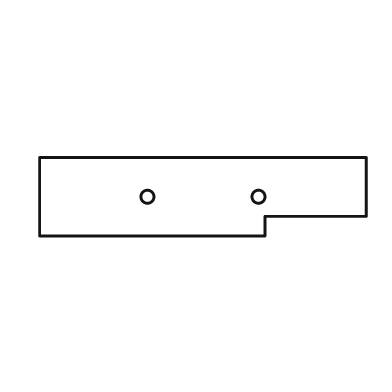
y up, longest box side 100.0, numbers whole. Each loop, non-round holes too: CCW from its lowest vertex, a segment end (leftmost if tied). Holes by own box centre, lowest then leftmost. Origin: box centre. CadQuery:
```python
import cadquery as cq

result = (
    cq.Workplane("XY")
    .moveTo(-50.0, -12.0)
    .lineTo(19.0, -12.0)
    .lineTo(19.0, -6.0)
    .lineTo(50.0, -6.0)
    .lineTo(50.0, 12.0)
    .lineTo(-50.0, 12.0)
    .close()
    .moveTo(-17.0, 0.0)
    .circle(2.0)
    .moveTo(17.0, 0.0)
    .circle(2.0)
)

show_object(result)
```